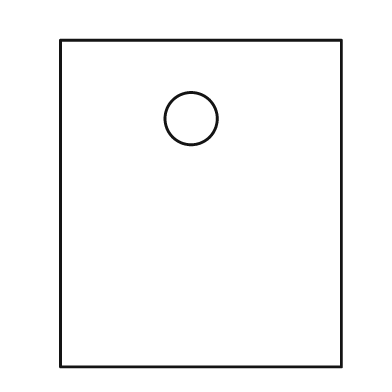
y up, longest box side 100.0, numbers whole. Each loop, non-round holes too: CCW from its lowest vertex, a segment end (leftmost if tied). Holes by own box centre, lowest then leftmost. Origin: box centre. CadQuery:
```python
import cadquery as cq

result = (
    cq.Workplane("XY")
    .moveTo(-43.0, -50.0)
    .lineTo(43.0, -50.0)
    .lineTo(43.0, 50.0)
    .lineTo(-43.0, 50.0)
    .close()
    .moveTo(-3.0, 26.0)
    .circle(8.0)
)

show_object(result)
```